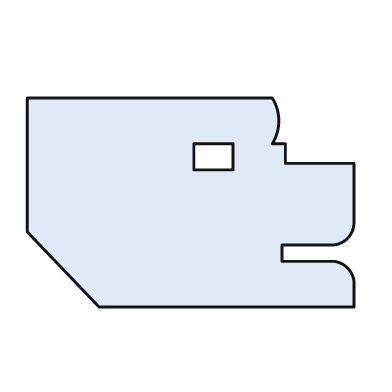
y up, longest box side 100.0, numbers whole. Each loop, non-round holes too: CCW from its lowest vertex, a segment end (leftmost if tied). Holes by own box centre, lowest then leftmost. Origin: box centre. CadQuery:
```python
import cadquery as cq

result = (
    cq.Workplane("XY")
    .moveTo(-28.0, -32.0)
    .lineTo(50.0, -32.0)
    .lineTo(50.0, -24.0)
    .threePointArc((48.0, -20.0), (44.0, -18.0))
    .lineTo(28.0, -18.0)
    .lineTo(28.0, -13.0)
    .lineTo(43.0, -13.0)
    .threePointArc((48.0, -11.0), (50.0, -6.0))
    .lineTo(50.0, 12.0)
    .lineTo(29.0, 12.0)
    .lineTo(29.0, 18.0)
    .lineTo(25.0, 18.0)
    .threePointArc((27.0, 25.0), (25.0, 32.0))
    .lineTo(-50.0, 32.0)
    .lineTo(-50.0, -9.0)
    .close()
    .moveTo(1.0, 10.0)
    .lineTo(13.0, 10.0)
    .lineTo(13.0, 18.0)
    .lineTo(1.0, 18.0)
    .close()
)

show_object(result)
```